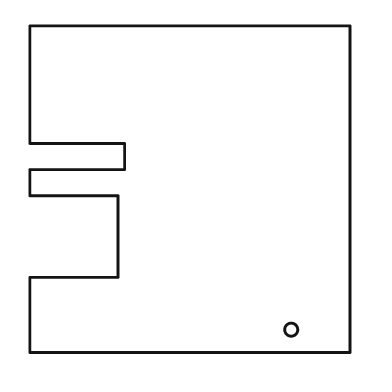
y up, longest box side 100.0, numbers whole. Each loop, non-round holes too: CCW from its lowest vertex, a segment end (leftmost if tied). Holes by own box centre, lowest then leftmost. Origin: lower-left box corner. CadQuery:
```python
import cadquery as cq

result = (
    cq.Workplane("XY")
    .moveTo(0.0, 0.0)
    .lineTo(98.0, 0.0)
    .lineTo(98.0, 100.0)
    .lineTo(0.0, 100.0)
    .lineTo(0.0, 64.0)
    .lineTo(29.0, 64.0)
    .lineTo(29.0, 56.0)
    .lineTo(0.0, 56.0)
    .lineTo(0.0, 48.0)
    .lineTo(27.0, 48.0)
    .lineTo(27.0, 23.0)
    .lineTo(0.0, 23.0)
    .close()
    .moveTo(80.0, 7.0)
    .circle(2.0)
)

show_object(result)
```